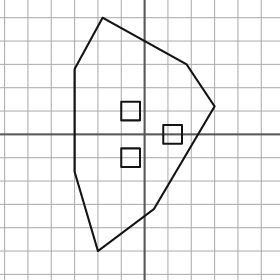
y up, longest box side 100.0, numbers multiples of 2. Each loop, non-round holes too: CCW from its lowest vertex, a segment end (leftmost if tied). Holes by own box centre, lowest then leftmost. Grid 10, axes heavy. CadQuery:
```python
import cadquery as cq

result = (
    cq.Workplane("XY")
    .moveTo(-20.0, -50.0)
    .lineTo(4.0, -32.0)
    .lineTo(30.0, 12.0)
    .lineTo(18.0, 30.0)
    .lineTo(-18.0, 50.0)
    .lineTo(-30.0, 28.0)
    .lineTo(-30.0, -16.0)
    .close()
    .moveTo(-10.0, -14.0)
    .lineTo(-2.0, -14.0)
    .lineTo(-2.0, -6.0)
    .lineTo(-10.0, -6.0)
    .close()
    .moveTo(8.0, -4.0)
    .lineTo(16.0, -4.0)
    .lineTo(16.0, 4.0)
    .lineTo(8.0, 4.0)
    .close()
    .moveTo(-10.0, 6.0)
    .lineTo(-2.0, 6.0)
    .lineTo(-2.0, 14.0)
    .lineTo(-10.0, 14.0)
    .close()
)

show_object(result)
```